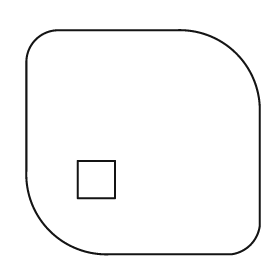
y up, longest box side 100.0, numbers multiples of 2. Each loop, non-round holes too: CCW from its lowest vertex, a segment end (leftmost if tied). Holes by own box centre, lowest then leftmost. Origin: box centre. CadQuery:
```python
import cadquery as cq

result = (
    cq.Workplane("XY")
    .moveTo(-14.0, -48.0)
    .lineTo(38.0, -48.0)
    .threePointArc((46.0, -44.0), (50.0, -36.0))
    .lineTo(50.0, 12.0)
    .threePointArc((40.0, 38.0), (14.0, 48.0))
    .lineTo(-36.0, 48.0)
    .threePointArc((-46.0, 44.0), (-50.0, 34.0))
    .lineTo(-50.0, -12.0)
    .threePointArc((-40.0, -38.0), (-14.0, -48.0))
    .close()
    .moveTo(-28.0, -24.0)
    .lineTo(-12.0, -24.0)
    .lineTo(-12.0, -8.0)
    .lineTo(-28.0, -8.0)
    .close()
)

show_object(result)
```